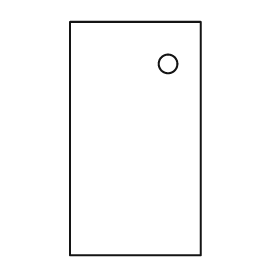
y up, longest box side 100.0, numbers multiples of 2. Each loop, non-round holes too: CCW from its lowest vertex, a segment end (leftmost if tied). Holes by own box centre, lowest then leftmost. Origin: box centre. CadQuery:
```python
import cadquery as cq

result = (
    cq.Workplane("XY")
    .moveTo(-28.0, -50.0)
    .lineTo(28.0, -50.0)
    .lineTo(28.0, 50.0)
    .lineTo(-28.0, 50.0)
    .close()
    .moveTo(14.0, 32.0)
    .circle(4.0)
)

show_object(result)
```